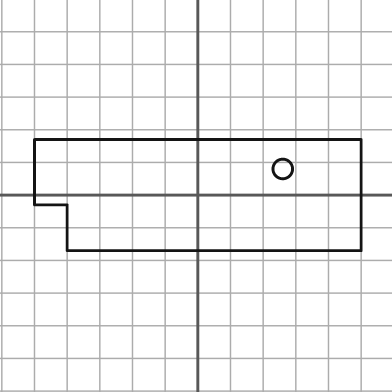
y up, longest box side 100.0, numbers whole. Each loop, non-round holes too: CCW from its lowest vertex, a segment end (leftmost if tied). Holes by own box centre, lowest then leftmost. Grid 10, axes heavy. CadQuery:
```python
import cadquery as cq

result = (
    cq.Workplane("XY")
    .moveTo(-40.0, -17.0)
    .lineTo(50.0, -17.0)
    .lineTo(50.0, 17.0)
    .lineTo(-50.0, 17.0)
    .lineTo(-50.0, -3.0)
    .lineTo(-40.0, -3.0)
    .close()
    .moveTo(26.0, 8.0)
    .circle(3.0)
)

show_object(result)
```